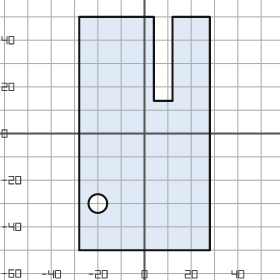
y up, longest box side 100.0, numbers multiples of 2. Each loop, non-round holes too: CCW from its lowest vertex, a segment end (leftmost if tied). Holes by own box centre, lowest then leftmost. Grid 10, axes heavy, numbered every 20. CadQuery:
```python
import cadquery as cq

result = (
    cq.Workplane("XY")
    .moveTo(-28.0, -50.0)
    .lineTo(28.0, -50.0)
    .lineTo(28.0, 50.0)
    .lineTo(12.0, 50.0)
    .lineTo(12.0, 14.0)
    .lineTo(4.0, 14.0)
    .lineTo(4.0, 50.0)
    .lineTo(-28.0, 50.0)
    .close()
    .moveTo(-20.0, -30.0)
    .circle(4.0)
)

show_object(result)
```